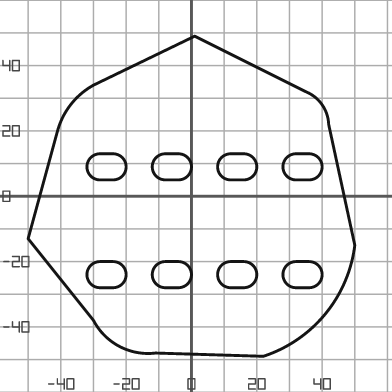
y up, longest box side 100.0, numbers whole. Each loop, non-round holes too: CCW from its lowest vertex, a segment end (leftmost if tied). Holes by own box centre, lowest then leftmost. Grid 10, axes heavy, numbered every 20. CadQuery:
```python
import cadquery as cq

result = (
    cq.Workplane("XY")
    .moveTo(22.0, -49.0)
    .threePointArc((41.0, -36.0), (50.0, -15.0))
    .lineTo(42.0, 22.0)
    .threePointArc((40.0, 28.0), (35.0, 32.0))
    .lineTo(1.0, 49.0)
    .lineTo(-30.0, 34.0)
    .threePointArc((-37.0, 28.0), (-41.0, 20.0))
    .lineTo(-50.0, -13.0)
    .lineTo(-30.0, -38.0)
    .threePointArc((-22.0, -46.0), (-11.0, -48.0))
    .close()
    .moveTo(-28.0, -28.0)
    .lineTo(-24.0, -28.0)
    .threePointArc((-20.0, -24.0), (-24.0, -20.0))
    .lineTo(-28.0, -20.0)
    .threePointArc((-32.0, -24.0), (-28.0, -28.0))
    .close()
    .moveTo(-8.0, -28.0)
    .lineTo(-4.0, -28.0)
    .threePointArc((0.0, -24.0), (-4.0, -20.0))
    .lineTo(-8.0, -20.0)
    .threePointArc((-12.0, -24.0), (-8.0, -28.0))
    .close()
    .moveTo(12.0, -28.0)
    .lineTo(16.0, -28.0)
    .threePointArc((20.0, -24.0), (16.0, -20.0))
    .lineTo(12.0, -20.0)
    .threePointArc((8.0, -24.0), (12.0, -28.0))
    .close()
    .moveTo(32.0, -28.0)
    .lineTo(36.0, -28.0)
    .threePointArc((40.0, -24.0), (36.0, -20.0))
    .lineTo(32.0, -20.0)
    .threePointArc((28.0, -24.0), (32.0, -28.0))
    .close()
    .moveTo(-28.0, 5.0)
    .lineTo(-24.0, 5.0)
    .threePointArc((-20.0, 9.0), (-24.0, 13.0))
    .lineTo(-28.0, 13.0)
    .threePointArc((-32.0, 9.0), (-28.0, 5.0))
    .close()
    .moveTo(-8.0, 5.0)
    .lineTo(-4.0, 5.0)
    .threePointArc((0.0, 9.0), (-4.0, 13.0))
    .lineTo(-8.0, 13.0)
    .threePointArc((-12.0, 9.0), (-8.0, 5.0))
    .close()
    .moveTo(12.0, 5.0)
    .lineTo(16.0, 5.0)
    .threePointArc((20.0, 9.0), (16.0, 13.0))
    .lineTo(12.0, 13.0)
    .threePointArc((8.0, 9.0), (12.0, 5.0))
    .close()
    .moveTo(32.0, 5.0)
    .lineTo(36.0, 5.0)
    .threePointArc((40.0, 9.0), (36.0, 13.0))
    .lineTo(32.0, 13.0)
    .threePointArc((28.0, 9.0), (32.0, 5.0))
    .close()
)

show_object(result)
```